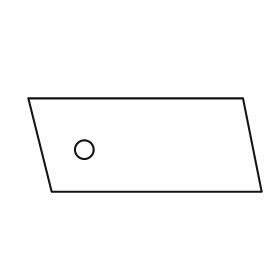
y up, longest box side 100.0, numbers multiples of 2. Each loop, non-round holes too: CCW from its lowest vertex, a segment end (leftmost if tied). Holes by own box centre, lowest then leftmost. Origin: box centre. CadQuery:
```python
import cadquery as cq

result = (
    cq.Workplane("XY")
    .moveTo(-40.0, -20.0)
    .lineTo(50.0, -20.0)
    .lineTo(42.0, 20.0)
    .lineTo(-50.0, 20.0)
    .close()
    .moveTo(-26.0, -2.0)
    .circle(4.0)
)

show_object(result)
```